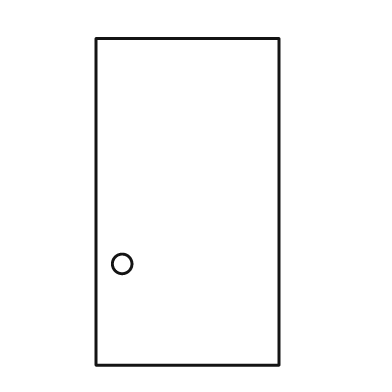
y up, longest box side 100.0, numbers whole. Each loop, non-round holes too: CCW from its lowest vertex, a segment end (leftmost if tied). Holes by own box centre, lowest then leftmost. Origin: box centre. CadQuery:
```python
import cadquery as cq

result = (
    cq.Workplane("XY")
    .moveTo(-28.0, -50.0)
    .lineTo(28.0, -50.0)
    .lineTo(28.0, 50.0)
    .lineTo(-28.0, 50.0)
    .close()
    .moveTo(-20.0, -19.0)
    .circle(3.0)
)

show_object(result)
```